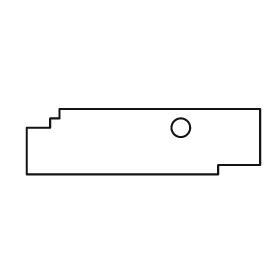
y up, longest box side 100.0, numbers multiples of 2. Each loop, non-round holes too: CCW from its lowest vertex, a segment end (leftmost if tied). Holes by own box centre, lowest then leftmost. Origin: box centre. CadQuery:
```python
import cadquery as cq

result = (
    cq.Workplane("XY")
    .moveTo(-50.0, -14.0)
    .lineTo(32.0, -14.0)
    .lineTo(32.0, -10.0)
    .lineTo(50.0, -10.0)
    .lineTo(50.0, 14.0)
    .lineTo(-36.0, 14.0)
    .lineTo(-36.0, 10.0)
    .lineTo(-40.0, 10.0)
    .lineTo(-40.0, 6.0)
    .lineTo(-50.0, 6.0)
    .close()
    .moveTo(16.0, 6.0)
    .circle(4.0)
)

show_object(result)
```